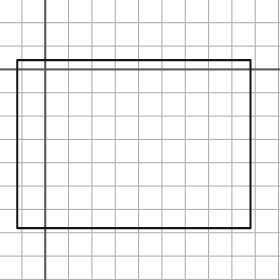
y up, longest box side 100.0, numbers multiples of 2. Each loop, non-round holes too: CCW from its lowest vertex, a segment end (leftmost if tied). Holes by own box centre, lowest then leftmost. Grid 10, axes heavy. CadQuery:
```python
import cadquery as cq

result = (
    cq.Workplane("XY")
    .moveTo(-12.0, -68.0)
    .lineTo(88.0, -68.0)
    .lineTo(88.0, 4.0)
    .lineTo(-12.0, 4.0)
    .close()
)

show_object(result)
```